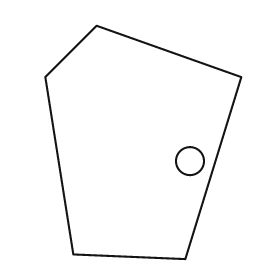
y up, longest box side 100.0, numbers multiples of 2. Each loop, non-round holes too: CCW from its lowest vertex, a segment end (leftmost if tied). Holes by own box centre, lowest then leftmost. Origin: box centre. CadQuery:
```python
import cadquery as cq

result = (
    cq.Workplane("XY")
    .moveTo(18.0, -50.0)
    .lineTo(42.0, 28.0)
    .lineTo(-20.0, 50.0)
    .lineTo(-42.0, 28.0)
    .lineTo(-30.0, -48.0)
    .close()
    .moveTo(20.0, -8.0)
    .circle(6.0)
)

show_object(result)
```